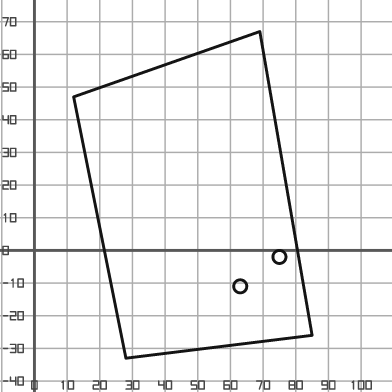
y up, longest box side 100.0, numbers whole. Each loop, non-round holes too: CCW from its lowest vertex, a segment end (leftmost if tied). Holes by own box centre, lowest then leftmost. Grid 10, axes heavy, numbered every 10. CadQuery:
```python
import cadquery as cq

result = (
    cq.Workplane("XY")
    .moveTo(28.0, -33.0)
    .lineTo(85.0, -26.0)
    .lineTo(69.0, 67.0)
    .lineTo(12.0, 47.0)
    .close()
    .moveTo(63.0, -11.0)
    .circle(2.0)
    .moveTo(75.0, -2.0)
    .circle(2.0)
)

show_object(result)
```